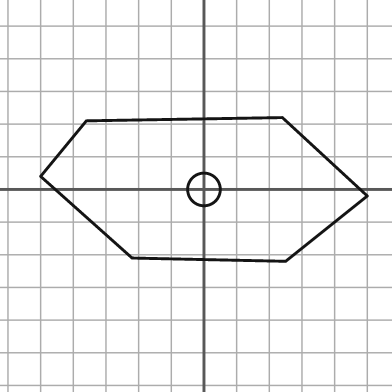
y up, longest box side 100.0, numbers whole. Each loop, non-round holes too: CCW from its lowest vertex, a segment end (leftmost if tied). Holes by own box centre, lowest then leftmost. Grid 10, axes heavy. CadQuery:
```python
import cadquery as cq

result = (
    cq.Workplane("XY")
    .moveTo(25.0, -22.0)
    .lineTo(50.0, -2.0)
    .lineTo(24.0, 22.0)
    .lineTo(-36.0, 21.0)
    .lineTo(-50.0, 4.0)
    .lineTo(-22.0, -21.0)
    .close()
    .moveTo(0.0, 0.0)
    .circle(5.0)
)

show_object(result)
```